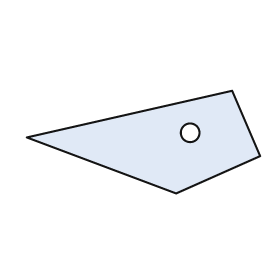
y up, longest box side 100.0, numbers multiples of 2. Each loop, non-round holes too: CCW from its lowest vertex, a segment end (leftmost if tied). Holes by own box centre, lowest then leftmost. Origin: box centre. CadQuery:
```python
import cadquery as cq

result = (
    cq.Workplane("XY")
    .moveTo(14.0, -22.0)
    .lineTo(50.0, -6.0)
    .lineTo(38.0, 22.0)
    .lineTo(-50.0, 2.0)
    .close()
    .moveTo(20.0, 4.0)
    .circle(4.0)
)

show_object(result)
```